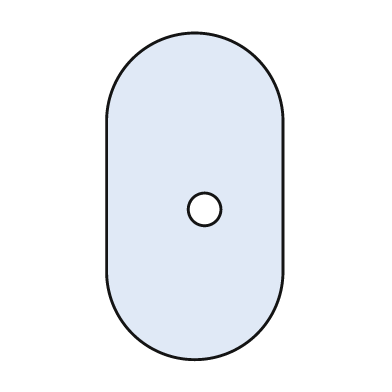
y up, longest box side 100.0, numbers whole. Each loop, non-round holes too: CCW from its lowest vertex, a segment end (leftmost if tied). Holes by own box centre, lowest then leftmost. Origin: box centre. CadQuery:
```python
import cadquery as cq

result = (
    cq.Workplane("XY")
    .moveTo(-27.0, -23.0)
    .threePointArc((0.0, -50.0), (27.0, -23.0))
    .lineTo(27.0, 23.0)
    .threePointArc((0.0, 50.0), (-27.0, 23.0))
    .close()
    .moveTo(3.0, -4.0)
    .circle(5.0)
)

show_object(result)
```